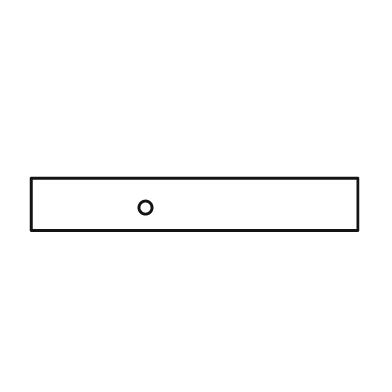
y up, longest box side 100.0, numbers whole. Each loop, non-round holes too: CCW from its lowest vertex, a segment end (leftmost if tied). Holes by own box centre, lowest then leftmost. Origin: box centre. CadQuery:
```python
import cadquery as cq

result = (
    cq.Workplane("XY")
    .moveTo(-50.0, -8.0)
    .lineTo(50.0, -8.0)
    .lineTo(50.0, 8.0)
    .lineTo(-50.0, 8.0)
    .close()
    .moveTo(-15.0, -1.0)
    .circle(2.0)
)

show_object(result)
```